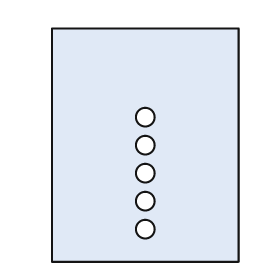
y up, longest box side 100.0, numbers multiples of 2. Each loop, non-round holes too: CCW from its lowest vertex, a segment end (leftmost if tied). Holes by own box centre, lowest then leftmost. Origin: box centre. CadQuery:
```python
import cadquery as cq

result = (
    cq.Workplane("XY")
    .moveTo(-40.0, -50.0)
    .lineTo(40.0, -50.0)
    .lineTo(40.0, 50.0)
    .lineTo(-40.0, 50.0)
    .close()
    .moveTo(0.0, -36.0)
    .circle(4.0)
    .moveTo(0.0, -24.0)
    .circle(4.0)
    .moveTo(0.0, -12.0)
    .circle(4.0)
    .moveTo(0.0, 0.0)
    .circle(4.0)
    .moveTo(0.0, 12.0)
    .circle(4.0)
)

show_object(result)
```